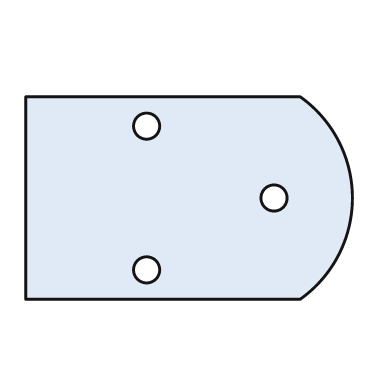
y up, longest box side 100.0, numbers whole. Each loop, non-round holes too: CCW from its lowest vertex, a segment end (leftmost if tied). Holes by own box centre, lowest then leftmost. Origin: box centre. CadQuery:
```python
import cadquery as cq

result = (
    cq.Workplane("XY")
    .moveTo(-50.0, -31.0)
    .lineTo(34.0, -31.0)
    .threePointArc((50.0, 0.0), (34.0, 31.0))
    .lineTo(-50.0, 31.0)
    .close()
    .moveTo(-13.0, -22.0)
    .circle(4.0)
    .moveTo(26.0, 0.0)
    .circle(4.0)
    .moveTo(-13.0, 22.0)
    .circle(4.0)
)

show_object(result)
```